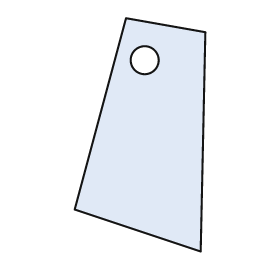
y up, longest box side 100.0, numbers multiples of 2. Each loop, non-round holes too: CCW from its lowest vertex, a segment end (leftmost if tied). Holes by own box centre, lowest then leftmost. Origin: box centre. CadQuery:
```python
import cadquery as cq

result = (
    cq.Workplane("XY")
    .moveTo(26.0, -50.0)
    .lineTo(28.0, 44.0)
    .lineTo(-6.0, 50.0)
    .lineTo(-28.0, -32.0)
    .close()
    .moveTo(2.0, 32.0)
    .circle(6.0)
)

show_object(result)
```